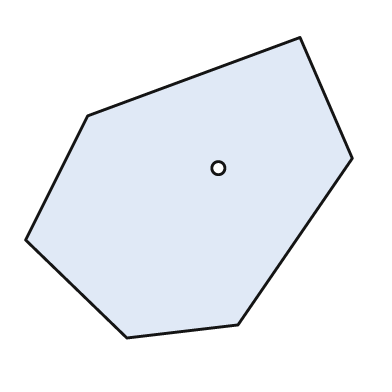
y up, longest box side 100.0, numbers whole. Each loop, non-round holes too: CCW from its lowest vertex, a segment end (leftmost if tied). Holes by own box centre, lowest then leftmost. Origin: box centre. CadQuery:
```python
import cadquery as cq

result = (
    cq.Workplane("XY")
    .moveTo(-19.0, -46.0)
    .lineTo(15.0, -42.0)
    .lineTo(50.0, 9.0)
    .lineTo(34.0, 46.0)
    .lineTo(-31.0, 22.0)
    .lineTo(-50.0, -16.0)
    .close()
    .moveTo(9.0, 6.0)
    .circle(2.0)
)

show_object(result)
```